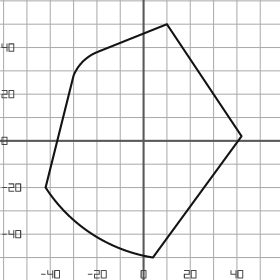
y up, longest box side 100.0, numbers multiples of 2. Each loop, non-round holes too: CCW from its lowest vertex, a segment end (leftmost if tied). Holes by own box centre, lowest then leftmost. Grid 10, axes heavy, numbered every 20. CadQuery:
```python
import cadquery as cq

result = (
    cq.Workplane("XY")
    .moveTo(4.0, -50.0)
    .lineTo(42.0, 2.0)
    .lineTo(10.0, 50.0)
    .lineTo(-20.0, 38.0)
    .threePointArc((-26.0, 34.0), (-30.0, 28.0))
    .lineTo(-42.0, -20.0)
    .threePointArc((-22.0, -40.0), (4.0, -50.0))
    .close()
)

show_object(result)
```